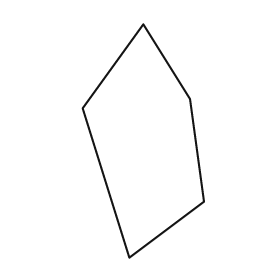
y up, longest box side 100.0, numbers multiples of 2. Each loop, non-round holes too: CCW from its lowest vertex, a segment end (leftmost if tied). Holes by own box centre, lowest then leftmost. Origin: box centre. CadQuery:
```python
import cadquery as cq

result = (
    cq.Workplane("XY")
    .moveTo(-6.0, -50.0)
    .lineTo(26.0, -26.0)
    .lineTo(20.0, 18.0)
    .lineTo(0.0, 50.0)
    .lineTo(-26.0, 14.0)
    .close()
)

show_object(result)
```